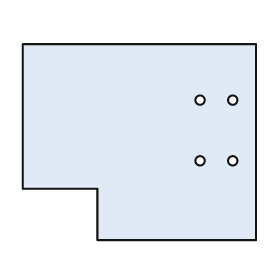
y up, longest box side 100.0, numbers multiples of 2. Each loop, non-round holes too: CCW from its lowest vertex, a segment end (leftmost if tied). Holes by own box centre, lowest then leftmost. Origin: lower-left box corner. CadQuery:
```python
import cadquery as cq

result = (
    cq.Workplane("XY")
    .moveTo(32.0, 0.0)
    .lineTo(100.0, 0.0)
    .lineTo(100.0, 84.0)
    .lineTo(0.0, 84.0)
    .lineTo(0.0, 22.0)
    .lineTo(32.0, 22.0)
    .close()
    .moveTo(76.0, 34.0)
    .circle(2.0)
    .moveTo(90.0, 34.0)
    .circle(2.0)
    .moveTo(76.0, 60.0)
    .circle(2.0)
    .moveTo(90.0, 60.0)
    .circle(2.0)
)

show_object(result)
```